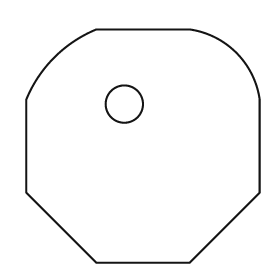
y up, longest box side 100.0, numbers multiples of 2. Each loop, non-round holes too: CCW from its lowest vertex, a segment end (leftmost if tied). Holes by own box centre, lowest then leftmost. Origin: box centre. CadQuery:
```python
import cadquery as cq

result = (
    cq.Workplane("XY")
    .moveTo(-20.0, -50.0)
    .lineTo(20.0, -50.0)
    .lineTo(50.0, -20.0)
    .lineTo(50.0, 20.0)
    .threePointArc((40.0, 40.0), (20.0, 50.0))
    .lineTo(-20.0, 50.0)
    .threePointArc((-38.0, 38.0), (-50.0, 20.0))
    .lineTo(-50.0, -20.0)
    .close()
    .moveTo(-8.0, 18.0)
    .circle(8.0)
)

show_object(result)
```